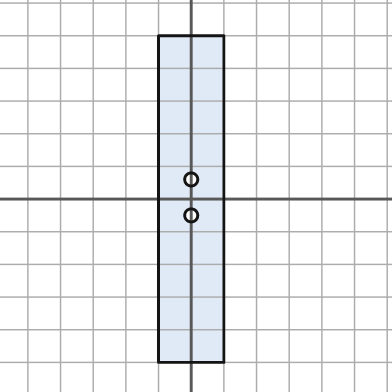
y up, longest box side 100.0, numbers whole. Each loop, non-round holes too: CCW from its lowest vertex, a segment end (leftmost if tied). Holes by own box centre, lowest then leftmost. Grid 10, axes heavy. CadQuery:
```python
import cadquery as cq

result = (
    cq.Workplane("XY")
    .moveTo(-10.0, -50.0)
    .lineTo(10.0, -50.0)
    .lineTo(10.0, 50.0)
    .lineTo(-10.0, 50.0)
    .close()
    .moveTo(0.0, -5.0)
    .circle(2.0)
    .moveTo(0.0, 6.0)
    .circle(2.0)
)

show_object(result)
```